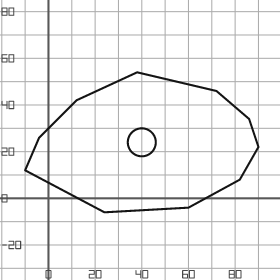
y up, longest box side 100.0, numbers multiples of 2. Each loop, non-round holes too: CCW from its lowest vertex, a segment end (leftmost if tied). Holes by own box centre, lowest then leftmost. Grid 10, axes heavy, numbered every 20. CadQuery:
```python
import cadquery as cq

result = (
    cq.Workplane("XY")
    .moveTo(24.0, -6.0)
    .lineTo(60.0, -4.0)
    .lineTo(82.0, 8.0)
    .lineTo(90.0, 22.0)
    .lineTo(86.0, 34.0)
    .lineTo(72.0, 46.0)
    .lineTo(38.0, 54.0)
    .lineTo(12.0, 42.0)
    .lineTo(-4.0, 26.0)
    .lineTo(-10.0, 12.0)
    .close()
    .moveTo(40.0, 24.0)
    .circle(6.0)
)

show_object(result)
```